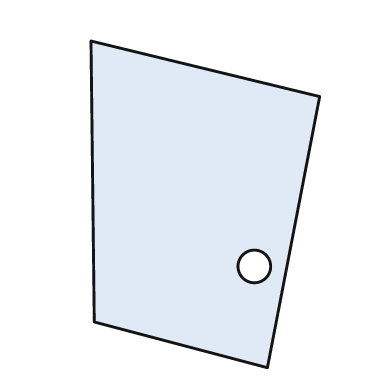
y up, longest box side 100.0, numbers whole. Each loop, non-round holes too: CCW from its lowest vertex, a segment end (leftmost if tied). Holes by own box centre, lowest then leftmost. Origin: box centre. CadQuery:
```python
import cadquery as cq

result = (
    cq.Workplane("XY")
    .moveTo(19.0, -50.0)
    .lineTo(35.0, 33.0)
    .lineTo(-35.0, 50.0)
    .lineTo(-34.0, -36.0)
    .close()
    .moveTo(15.0, -19.0)
    .circle(5.0)
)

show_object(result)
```